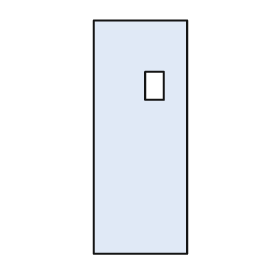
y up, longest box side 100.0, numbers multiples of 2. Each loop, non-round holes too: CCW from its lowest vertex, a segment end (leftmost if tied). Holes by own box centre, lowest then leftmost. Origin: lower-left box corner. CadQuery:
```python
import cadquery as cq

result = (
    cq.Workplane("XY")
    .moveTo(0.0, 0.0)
    .lineTo(40.0, 0.0)
    .lineTo(40.0, 100.0)
    .lineTo(0.0, 100.0)
    .close()
    .moveTo(22.0, 66.0)
    .lineTo(30.0, 66.0)
    .lineTo(30.0, 78.0)
    .lineTo(22.0, 78.0)
    .close()
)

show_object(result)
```